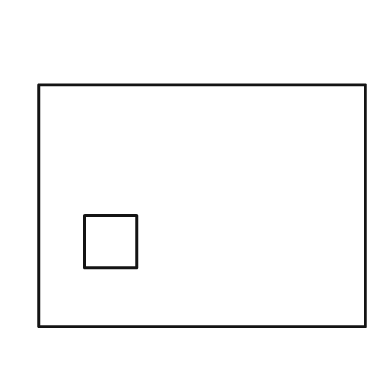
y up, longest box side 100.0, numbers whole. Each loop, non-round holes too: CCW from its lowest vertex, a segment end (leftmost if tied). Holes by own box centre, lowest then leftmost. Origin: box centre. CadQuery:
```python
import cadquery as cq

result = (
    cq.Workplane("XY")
    .moveTo(-50.0, -37.0)
    .lineTo(50.0, -37.0)
    .lineTo(50.0, 37.0)
    .lineTo(-50.0, 37.0)
    .close()
    .moveTo(-36.0, -19.0)
    .lineTo(-20.0, -19.0)
    .lineTo(-20.0, -3.0)
    .lineTo(-36.0, -3.0)
    .close()
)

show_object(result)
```